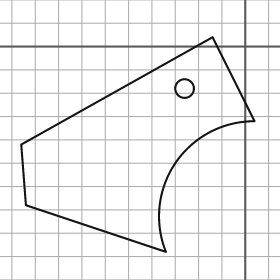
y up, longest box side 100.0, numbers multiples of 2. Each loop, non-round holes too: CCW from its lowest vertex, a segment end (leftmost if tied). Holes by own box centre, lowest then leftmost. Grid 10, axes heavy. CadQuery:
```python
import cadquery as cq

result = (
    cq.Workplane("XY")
    .moveTo(-34.0, -88.0)
    .threePointArc((-30.0, -50.0), (4.0, -32.0))
    .lineTo(-14.0, 4.0)
    .lineTo(-96.0, -42.0)
    .lineTo(-94.0, -68.0)
    .close()
    .moveTo(-26.0, -18.0)
    .circle(4.0)
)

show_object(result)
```